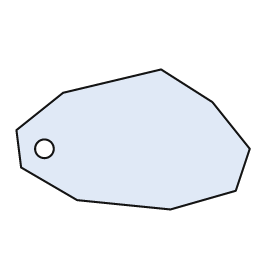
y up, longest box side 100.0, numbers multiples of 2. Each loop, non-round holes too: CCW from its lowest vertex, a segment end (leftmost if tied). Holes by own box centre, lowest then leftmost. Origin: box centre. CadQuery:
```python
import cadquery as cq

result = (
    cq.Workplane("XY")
    .moveTo(16.0, -30.0)
    .lineTo(44.0, -22.0)
    .lineTo(50.0, -4.0)
    .lineTo(34.0, 16.0)
    .lineTo(12.0, 30.0)
    .lineTo(-30.0, 20.0)
    .lineTo(-50.0, 4.0)
    .lineTo(-48.0, -12.0)
    .lineTo(-24.0, -26.0)
    .close()
    .moveTo(-38.0, -4.0)
    .circle(4.0)
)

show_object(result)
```